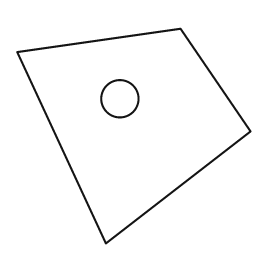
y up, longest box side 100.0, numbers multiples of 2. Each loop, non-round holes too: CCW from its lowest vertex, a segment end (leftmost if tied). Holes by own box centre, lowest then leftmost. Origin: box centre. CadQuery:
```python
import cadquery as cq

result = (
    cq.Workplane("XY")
    .moveTo(-12.0, -46.0)
    .lineTo(50.0, 2.0)
    .lineTo(20.0, 46.0)
    .lineTo(-50.0, 36.0)
    .close()
    .moveTo(-6.0, 16.0)
    .circle(8.0)
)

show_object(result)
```